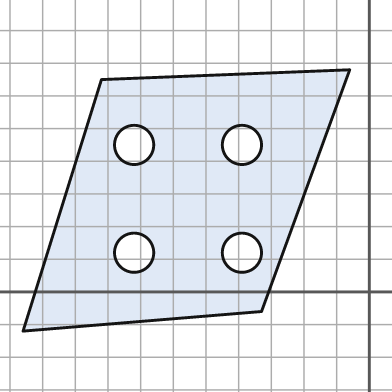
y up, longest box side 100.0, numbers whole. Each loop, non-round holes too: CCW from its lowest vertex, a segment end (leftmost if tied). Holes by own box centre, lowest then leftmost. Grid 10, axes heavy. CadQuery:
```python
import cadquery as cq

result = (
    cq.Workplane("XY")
    .moveTo(-106.0, -12.0)
    .lineTo(-33.0, -6.0)
    .lineTo(-6.0, 68.0)
    .lineTo(-82.0, 65.0)
    .close()
    .moveTo(-72.0, 12.0)
    .circle(6.0)
    .moveTo(-39.0, 12.0)
    .circle(6.0)
    .moveTo(-72.0, 45.0)
    .circle(6.0)
    .moveTo(-39.0, 45.0)
    .circle(6.0)
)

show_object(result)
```